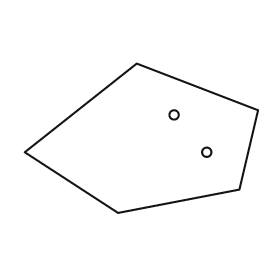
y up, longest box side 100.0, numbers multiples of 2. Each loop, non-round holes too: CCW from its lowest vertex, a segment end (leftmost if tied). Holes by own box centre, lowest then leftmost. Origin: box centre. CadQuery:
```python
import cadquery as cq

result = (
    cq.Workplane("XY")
    .moveTo(-10.0, -32.0)
    .lineTo(42.0, -22.0)
    .lineTo(50.0, 12.0)
    .lineTo(-2.0, 32.0)
    .lineTo(-50.0, -6.0)
    .close()
    .moveTo(28.0, -6.0)
    .circle(2.0)
    .moveTo(14.0, 10.0)
    .circle(2.0)
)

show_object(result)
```